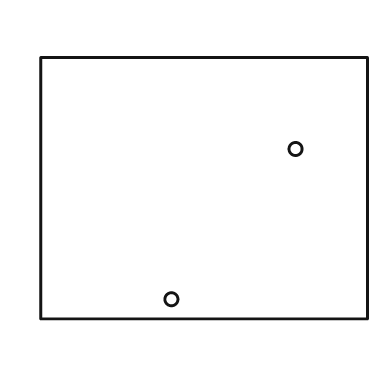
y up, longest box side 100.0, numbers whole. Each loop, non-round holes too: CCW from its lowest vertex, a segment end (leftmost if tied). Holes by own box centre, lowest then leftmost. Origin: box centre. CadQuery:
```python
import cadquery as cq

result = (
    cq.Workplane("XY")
    .moveTo(-50.0, -40.0)
    .lineTo(50.0, -40.0)
    .lineTo(50.0, 40.0)
    .lineTo(-50.0, 40.0)
    .close()
    .moveTo(-10.0, -34.0)
    .circle(2.0)
    .moveTo(28.0, 12.0)
    .circle(2.0)
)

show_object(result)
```